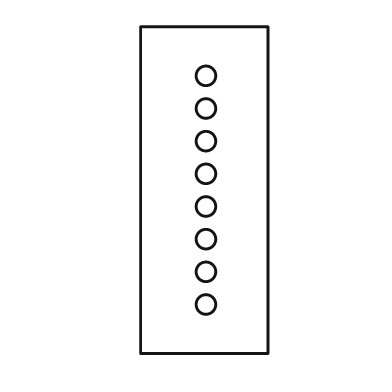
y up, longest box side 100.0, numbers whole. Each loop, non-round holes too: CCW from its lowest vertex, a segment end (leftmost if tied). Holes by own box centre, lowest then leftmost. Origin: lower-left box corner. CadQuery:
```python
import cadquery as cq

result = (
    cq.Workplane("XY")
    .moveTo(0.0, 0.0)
    .lineTo(39.0, 0.0)
    .lineTo(39.0, 100.0)
    .lineTo(0.0, 100.0)
    .close()
    .moveTo(20.0, 15.0)
    .circle(3.0)
    .moveTo(20.0, 25.0)
    .circle(3.0)
    .moveTo(20.0, 35.0)
    .circle(3.0)
    .moveTo(20.0, 45.0)
    .circle(3.0)
    .moveTo(20.0, 55.0)
    .circle(3.0)
    .moveTo(20.0, 65.0)
    .circle(3.0)
    .moveTo(20.0, 75.0)
    .circle(3.0)
    .moveTo(20.0, 85.0)
    .circle(3.0)
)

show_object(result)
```